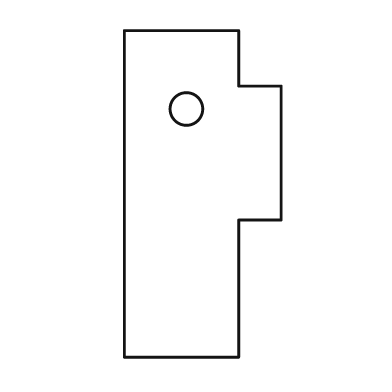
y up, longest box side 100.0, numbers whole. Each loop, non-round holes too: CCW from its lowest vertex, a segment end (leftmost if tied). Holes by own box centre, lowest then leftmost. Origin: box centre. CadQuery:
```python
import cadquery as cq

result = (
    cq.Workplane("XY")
    .moveTo(-24.0, -50.0)
    .lineTo(11.0, -50.0)
    .lineTo(11.0, -8.0)
    .lineTo(24.0, -8.0)
    .lineTo(24.0, 33.0)
    .lineTo(11.0, 33.0)
    .lineTo(11.0, 50.0)
    .lineTo(-24.0, 50.0)
    .close()
    .moveTo(-5.0, 26.0)
    .circle(5.0)
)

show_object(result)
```